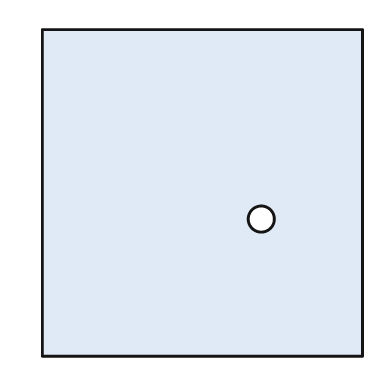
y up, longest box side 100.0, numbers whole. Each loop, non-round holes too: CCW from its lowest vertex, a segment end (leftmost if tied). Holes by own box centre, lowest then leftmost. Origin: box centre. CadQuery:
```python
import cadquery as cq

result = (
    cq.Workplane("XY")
    .moveTo(-49.0, -50.0)
    .lineTo(49.0, -50.0)
    .lineTo(49.0, 50.0)
    .lineTo(-49.0, 50.0)
    .close()
    .moveTo(18.0, -8.0)
    .circle(4.0)
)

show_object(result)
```